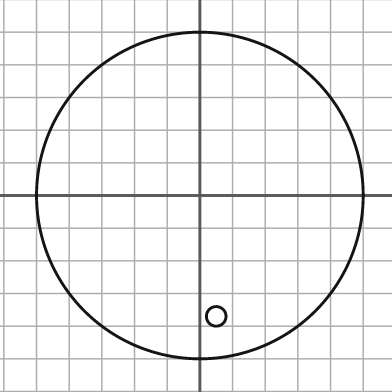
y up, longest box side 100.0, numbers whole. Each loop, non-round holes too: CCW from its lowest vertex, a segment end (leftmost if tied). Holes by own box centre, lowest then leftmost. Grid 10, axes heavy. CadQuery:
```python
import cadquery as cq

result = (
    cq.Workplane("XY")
    .moveTo(0.0, 0.0)
    .circle(50.0)
    .moveTo(5.0, -37.0)
    .circle(3.0)
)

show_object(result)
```